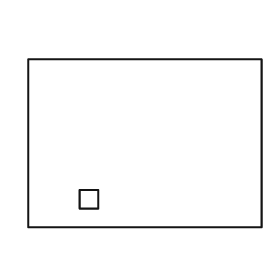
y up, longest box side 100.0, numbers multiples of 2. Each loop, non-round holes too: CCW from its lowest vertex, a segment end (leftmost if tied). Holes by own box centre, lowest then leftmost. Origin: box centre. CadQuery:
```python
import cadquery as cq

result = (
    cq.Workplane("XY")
    .moveTo(-50.0, -36.0)
    .lineTo(50.0, -36.0)
    .lineTo(50.0, 36.0)
    .lineTo(-50.0, 36.0)
    .close()
    .moveTo(-28.0, -28.0)
    .lineTo(-20.0, -28.0)
    .lineTo(-20.0, -20.0)
    .lineTo(-28.0, -20.0)
    .close()
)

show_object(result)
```